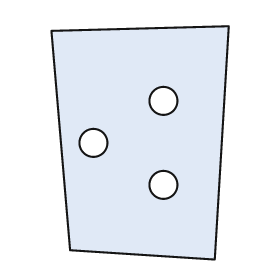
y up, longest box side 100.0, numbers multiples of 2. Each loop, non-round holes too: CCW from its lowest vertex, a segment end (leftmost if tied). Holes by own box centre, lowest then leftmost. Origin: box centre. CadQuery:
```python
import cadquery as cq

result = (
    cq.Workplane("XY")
    .moveTo(32.0, -50.0)
    .lineTo(38.0, 50.0)
    .lineTo(-38.0, 48.0)
    .lineTo(-30.0, -46.0)
    .close()
    .moveTo(10.0, -18.0)
    .circle(6.0)
    .moveTo(-20.0, 0.0)
    .circle(6.0)
    .moveTo(10.0, 18.0)
    .circle(6.0)
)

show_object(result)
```